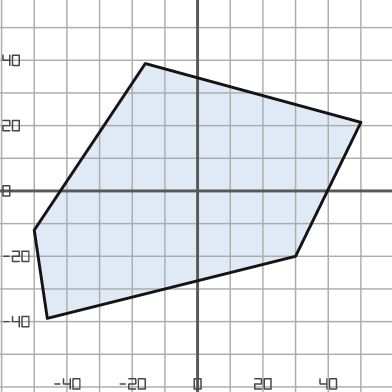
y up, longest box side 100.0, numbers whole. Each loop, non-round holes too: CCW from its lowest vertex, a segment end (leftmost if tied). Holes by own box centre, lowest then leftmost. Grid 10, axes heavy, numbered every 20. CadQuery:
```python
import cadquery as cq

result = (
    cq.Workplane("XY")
    .moveTo(-46.0, -39.0)
    .lineTo(30.0, -20.0)
    .lineTo(50.0, 21.0)
    .lineTo(-16.0, 39.0)
    .lineTo(-50.0, -12.0)
    .close()
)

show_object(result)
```